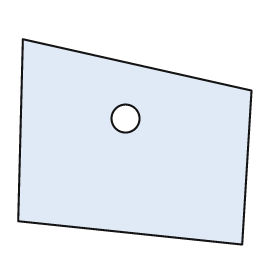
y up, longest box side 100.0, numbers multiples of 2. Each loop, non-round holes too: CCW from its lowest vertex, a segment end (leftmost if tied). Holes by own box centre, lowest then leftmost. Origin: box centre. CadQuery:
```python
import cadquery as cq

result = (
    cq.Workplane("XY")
    .moveTo(46.0, -44.0)
    .lineTo(50.0, 22.0)
    .lineTo(-48.0, 44.0)
    .lineTo(-50.0, -34.0)
    .close()
    .moveTo(-4.0, 10.0)
    .circle(6.0)
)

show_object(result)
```